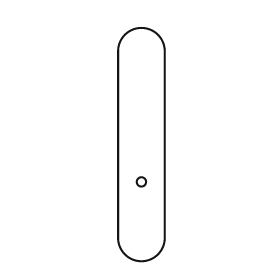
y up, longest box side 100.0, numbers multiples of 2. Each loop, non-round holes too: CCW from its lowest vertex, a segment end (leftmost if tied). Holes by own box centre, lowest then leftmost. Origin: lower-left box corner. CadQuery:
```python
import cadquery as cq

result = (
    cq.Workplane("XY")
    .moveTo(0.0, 10.0)
    .threePointArc((10.0, 0.0), (20.0, 10.0))
    .lineTo(20.0, 90.0)
    .threePointArc((10.0, 100.0), (0.0, 90.0))
    .close()
    .moveTo(10.0, 34.0)
    .circle(2.0)
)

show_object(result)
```